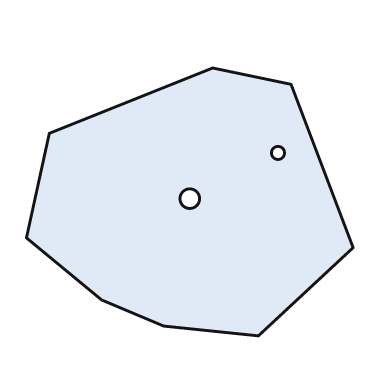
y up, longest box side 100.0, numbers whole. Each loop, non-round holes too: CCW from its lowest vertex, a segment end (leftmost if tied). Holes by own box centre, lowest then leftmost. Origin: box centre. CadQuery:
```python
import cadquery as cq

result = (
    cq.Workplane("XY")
    .moveTo(21.0, -41.0)
    .lineTo(50.0, -14.0)
    .lineTo(31.0, 36.0)
    .lineTo(7.0, 41.0)
    .lineTo(-43.0, 21.0)
    .lineTo(-50.0, -11.0)
    .lineTo(-27.0, -30.0)
    .lineTo(-8.0, -38.0)
    .close()
    .moveTo(0.0, 1.0)
    .circle(3.0)
    .moveTo(27.0, 15.0)
    .circle(2.0)
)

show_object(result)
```